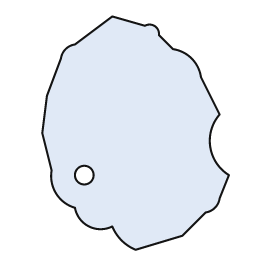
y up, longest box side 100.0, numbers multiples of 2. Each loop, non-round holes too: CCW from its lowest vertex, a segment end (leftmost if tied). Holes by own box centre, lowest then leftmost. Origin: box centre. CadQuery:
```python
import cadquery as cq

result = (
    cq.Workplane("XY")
    .moveTo(0.0, -50.0)
    .lineTo(20.0, -44.0)
    .lineTo(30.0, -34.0)
    .threePointArc((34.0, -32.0), (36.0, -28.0))
    .lineTo(40.0, -18.0)
    .threePointArc((32.0, -6.0), (36.0, 8.0))
    .lineTo(28.0, 24.0)
    .threePointArc((24.0, 32.0), (16.0, 36.0))
    .lineTo(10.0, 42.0)
    .threePointArc((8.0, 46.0), (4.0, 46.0))
    .lineTo(-10.0, 50.0)
    .lineTo(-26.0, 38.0)
    .threePointArc((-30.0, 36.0), (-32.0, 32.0))
    .lineTo(-38.0, 16.0)
    .lineTo(-40.0, 0.0)
    .lineTo(-36.0, -16.0)
    .threePointArc((-34.0, -26.0), (-26.0, -32.0))
    .threePointArc((-20.0, -40.0), (-10.0, -40.0))
    .threePointArc((-6.0, -46.0), (0.0, -50.0))
    .close()
    .moveTo(-22.0, -18.0)
    .circle(4.0)
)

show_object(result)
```